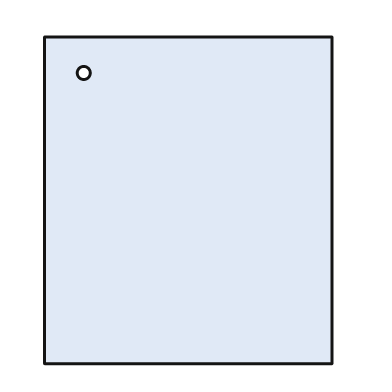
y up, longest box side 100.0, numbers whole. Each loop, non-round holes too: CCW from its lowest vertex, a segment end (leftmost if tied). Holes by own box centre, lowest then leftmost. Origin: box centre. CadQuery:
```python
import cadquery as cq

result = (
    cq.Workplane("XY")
    .moveTo(-44.0, -50.0)
    .lineTo(44.0, -50.0)
    .lineTo(44.0, 50.0)
    .lineTo(-44.0, 50.0)
    .close()
    .moveTo(-32.0, 39.0)
    .circle(2.0)
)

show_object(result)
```